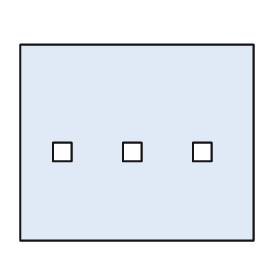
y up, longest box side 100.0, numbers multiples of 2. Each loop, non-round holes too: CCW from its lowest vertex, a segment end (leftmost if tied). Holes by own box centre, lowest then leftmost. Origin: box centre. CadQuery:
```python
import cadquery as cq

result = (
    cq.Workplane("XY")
    .moveTo(-50.0, -42.0)
    .lineTo(50.0, -42.0)
    .lineTo(50.0, 42.0)
    .lineTo(-50.0, 42.0)
    .close()
    .moveTo(-36.0, -8.0)
    .lineTo(-28.0, -8.0)
    .lineTo(-28.0, 0.0)
    .lineTo(-36.0, 0.0)
    .close()
    .moveTo(-6.0, -8.0)
    .lineTo(2.0, -8.0)
    .lineTo(2.0, 0.0)
    .lineTo(-6.0, 0.0)
    .close()
    .moveTo(24.0, -8.0)
    .lineTo(32.0, -8.0)
    .lineTo(32.0, 0.0)
    .lineTo(24.0, 0.0)
    .close()
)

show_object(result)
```